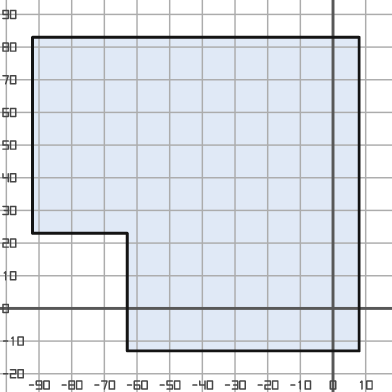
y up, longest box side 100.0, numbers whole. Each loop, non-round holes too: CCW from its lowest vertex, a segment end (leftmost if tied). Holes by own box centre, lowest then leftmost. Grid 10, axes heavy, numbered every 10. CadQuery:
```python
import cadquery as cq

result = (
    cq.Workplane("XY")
    .moveTo(-63.0, -13.0)
    .lineTo(8.0, -13.0)
    .lineTo(8.0, 83.0)
    .lineTo(-92.0, 83.0)
    .lineTo(-92.0, 23.0)
    .lineTo(-63.0, 23.0)
    .close()
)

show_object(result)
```